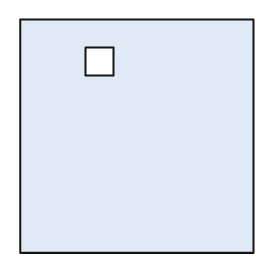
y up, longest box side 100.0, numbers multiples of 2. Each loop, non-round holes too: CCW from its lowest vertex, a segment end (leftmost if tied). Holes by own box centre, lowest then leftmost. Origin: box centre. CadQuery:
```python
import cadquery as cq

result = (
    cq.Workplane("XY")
    .moveTo(-50.0, -50.0)
    .lineTo(50.0, -50.0)
    .lineTo(50.0, 50.0)
    .lineTo(-50.0, 50.0)
    .close()
    .moveTo(-22.0, 26.0)
    .lineTo(-10.0, 26.0)
    .lineTo(-10.0, 38.0)
    .lineTo(-22.0, 38.0)
    .close()
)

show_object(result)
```